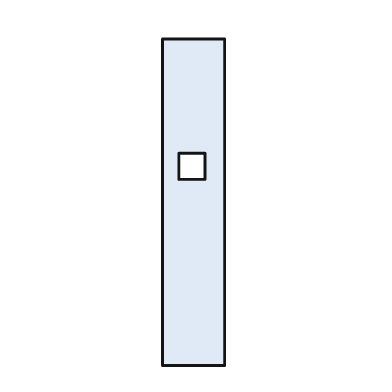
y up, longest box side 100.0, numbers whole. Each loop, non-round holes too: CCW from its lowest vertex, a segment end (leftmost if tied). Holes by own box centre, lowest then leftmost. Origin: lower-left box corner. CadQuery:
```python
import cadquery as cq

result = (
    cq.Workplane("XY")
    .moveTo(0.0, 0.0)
    .lineTo(19.0, 0.0)
    .lineTo(19.0, 100.0)
    .lineTo(0.0, 100.0)
    .close()
    .moveTo(5.0, 57.0)
    .lineTo(13.0, 57.0)
    .lineTo(13.0, 65.0)
    .lineTo(5.0, 65.0)
    .close()
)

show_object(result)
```